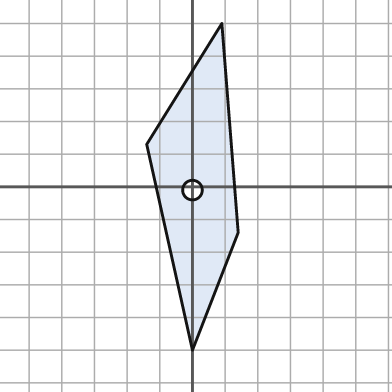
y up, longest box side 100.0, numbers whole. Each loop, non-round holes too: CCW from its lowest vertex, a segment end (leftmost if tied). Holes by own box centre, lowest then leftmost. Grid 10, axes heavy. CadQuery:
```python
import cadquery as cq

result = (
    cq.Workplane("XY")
    .moveTo(0.0, -50.0)
    .lineTo(14.0, -14.0)
    .lineTo(9.0, 50.0)
    .lineTo(-14.0, 13.0)
    .close()
    .moveTo(0.0, -1.0)
    .circle(3.0)
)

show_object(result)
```